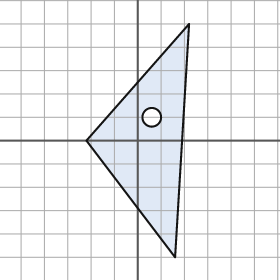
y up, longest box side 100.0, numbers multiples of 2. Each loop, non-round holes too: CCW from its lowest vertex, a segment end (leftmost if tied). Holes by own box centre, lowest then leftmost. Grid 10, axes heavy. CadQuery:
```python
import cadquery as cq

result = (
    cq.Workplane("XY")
    .moveTo(16.0, -50.0)
    .lineTo(22.0, 50.0)
    .lineTo(-22.0, 0.0)
    .close()
    .moveTo(6.0, 10.0)
    .circle(4.0)
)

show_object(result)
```